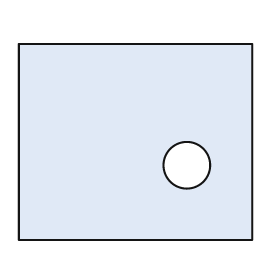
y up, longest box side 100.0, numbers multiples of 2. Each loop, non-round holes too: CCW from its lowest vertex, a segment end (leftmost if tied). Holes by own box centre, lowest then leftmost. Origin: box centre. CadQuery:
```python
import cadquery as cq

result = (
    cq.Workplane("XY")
    .moveTo(-50.0, -42.0)
    .lineTo(50.0, -42.0)
    .lineTo(50.0, 42.0)
    .lineTo(-50.0, 42.0)
    .close()
    .moveTo(22.0, -10.0)
    .circle(10.0)
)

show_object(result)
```